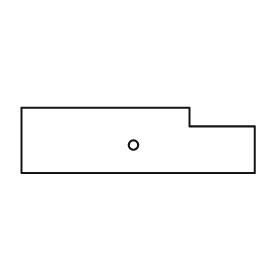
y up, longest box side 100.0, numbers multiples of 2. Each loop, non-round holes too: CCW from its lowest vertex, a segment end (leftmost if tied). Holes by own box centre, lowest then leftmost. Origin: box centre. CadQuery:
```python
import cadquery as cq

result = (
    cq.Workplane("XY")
    .moveTo(-50.0, -14.0)
    .lineTo(50.0, -14.0)
    .lineTo(50.0, 6.0)
    .lineTo(22.0, 6.0)
    .lineTo(22.0, 14.0)
    .lineTo(-50.0, 14.0)
    .close()
    .moveTo(-2.0, -2.0)
    .circle(2.0)
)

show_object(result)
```